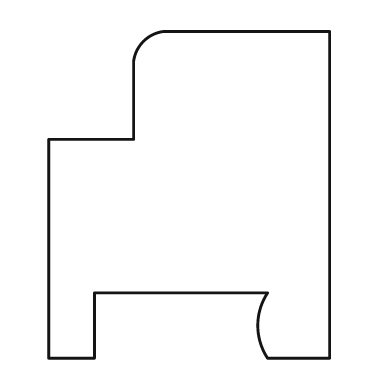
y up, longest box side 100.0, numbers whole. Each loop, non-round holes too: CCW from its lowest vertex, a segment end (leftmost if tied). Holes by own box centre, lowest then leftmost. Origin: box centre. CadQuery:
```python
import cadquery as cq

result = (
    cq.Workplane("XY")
    .moveTo(-43.0, -50.0)
    .lineTo(-29.0, -50.0)
    .lineTo(-29.0, -30.0)
    .lineTo(24.0, -30.0)
    .threePointArc((21.0, -40.0), (24.0, -50.0))
    .lineTo(43.0, -50.0)
    .lineTo(43.0, 50.0)
    .lineTo(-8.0, 50.0)
    .threePointArc((-14.0, 47.0), (-17.0, 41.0))
    .lineTo(-17.0, 17.0)
    .lineTo(-43.0, 17.0)
    .close()
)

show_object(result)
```